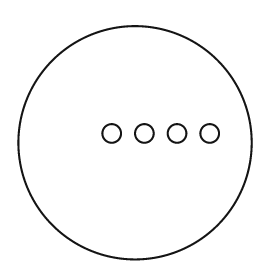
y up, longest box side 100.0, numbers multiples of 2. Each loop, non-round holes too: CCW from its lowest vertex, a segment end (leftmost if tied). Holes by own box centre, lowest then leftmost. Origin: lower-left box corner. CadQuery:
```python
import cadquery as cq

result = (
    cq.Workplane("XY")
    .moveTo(50.0, 50.0)
    .circle(50.0)
    .moveTo(40.0, 54.0)
    .circle(4.0)
    .moveTo(54.0, 54.0)
    .circle(4.0)
    .moveTo(68.0, 54.0)
    .circle(4.0)
    .moveTo(82.0, 54.0)
    .circle(4.0)
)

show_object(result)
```